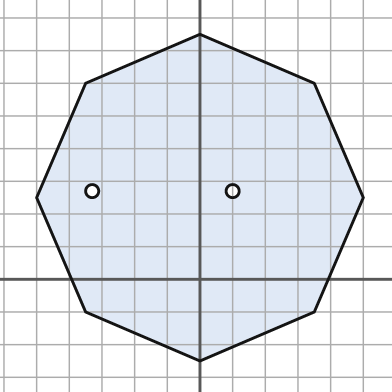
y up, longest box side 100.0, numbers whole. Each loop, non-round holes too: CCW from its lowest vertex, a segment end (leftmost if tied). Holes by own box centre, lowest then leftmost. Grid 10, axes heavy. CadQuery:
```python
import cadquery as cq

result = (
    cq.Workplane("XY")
    .moveTo(0.0, -25.0)
    .lineTo(35.0, -10.0)
    .lineTo(50.0, 25.0)
    .lineTo(35.0, 60.0)
    .lineTo(0.0, 75.0)
    .lineTo(-35.0, 60.0)
    .lineTo(-50.0, 25.0)
    .lineTo(-35.0, -10.0)
    .close()
    .moveTo(-33.0, 27.0)
    .circle(2.0)
    .moveTo(10.0, 27.0)
    .circle(2.0)
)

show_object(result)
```